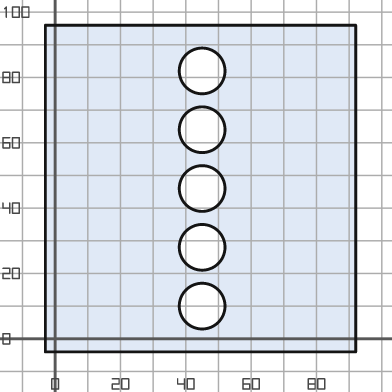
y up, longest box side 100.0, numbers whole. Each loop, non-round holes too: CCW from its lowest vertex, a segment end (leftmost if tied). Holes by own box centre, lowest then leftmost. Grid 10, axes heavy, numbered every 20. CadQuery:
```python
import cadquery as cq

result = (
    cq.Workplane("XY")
    .moveTo(-3.0, -4.0)
    .lineTo(92.0, -4.0)
    .lineTo(92.0, 96.0)
    .lineTo(-3.0, 96.0)
    .close()
    .moveTo(45.0, 10.0)
    .circle(7.0)
    .moveTo(45.0, 28.0)
    .circle(7.0)
    .moveTo(45.0, 46.0)
    .circle(7.0)
    .moveTo(45.0, 64.0)
    .circle(7.0)
    .moveTo(45.0, 82.0)
    .circle(7.0)
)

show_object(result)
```